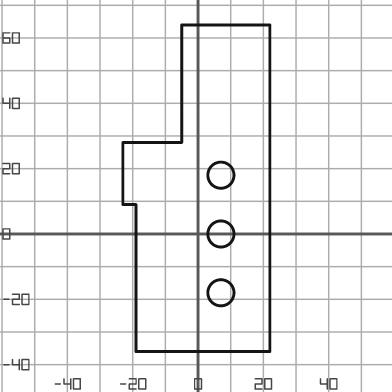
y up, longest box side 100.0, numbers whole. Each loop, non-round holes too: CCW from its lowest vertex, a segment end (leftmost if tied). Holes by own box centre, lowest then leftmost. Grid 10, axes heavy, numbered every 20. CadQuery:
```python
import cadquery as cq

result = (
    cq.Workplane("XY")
    .moveTo(-19.0, -36.0)
    .lineTo(22.0, -36.0)
    .lineTo(22.0, 64.0)
    .lineTo(-5.0, 64.0)
    .lineTo(-5.0, 28.0)
    .lineTo(-23.0, 28.0)
    .lineTo(-23.0, 9.0)
    .lineTo(-19.0, 9.0)
    .close()
    .moveTo(7.0, -18.0)
    .circle(4.0)
    .moveTo(7.0, 0.0)
    .circle(4.0)
    .moveTo(7.0, 18.0)
    .circle(4.0)
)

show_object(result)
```